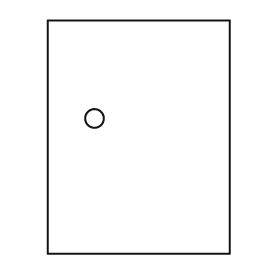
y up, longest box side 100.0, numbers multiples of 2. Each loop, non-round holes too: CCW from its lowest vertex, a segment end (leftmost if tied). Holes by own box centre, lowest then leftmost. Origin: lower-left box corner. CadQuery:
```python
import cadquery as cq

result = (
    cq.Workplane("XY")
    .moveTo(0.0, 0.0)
    .lineTo(78.0, 0.0)
    .lineTo(78.0, 100.0)
    .lineTo(0.0, 100.0)
    .close()
    .moveTo(20.0, 58.0)
    .circle(4.0)
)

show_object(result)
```